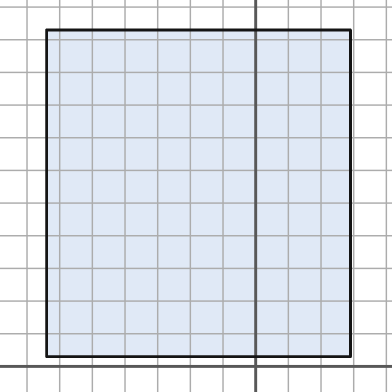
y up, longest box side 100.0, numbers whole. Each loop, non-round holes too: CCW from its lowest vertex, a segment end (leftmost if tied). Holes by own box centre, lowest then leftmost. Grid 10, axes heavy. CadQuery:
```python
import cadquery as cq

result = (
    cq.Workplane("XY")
    .moveTo(-64.0, 3.0)
    .lineTo(29.0, 3.0)
    .lineTo(29.0, 103.0)
    .lineTo(-64.0, 103.0)
    .close()
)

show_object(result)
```